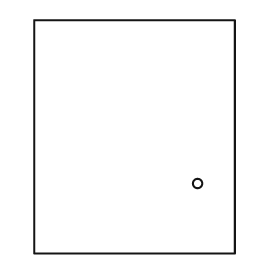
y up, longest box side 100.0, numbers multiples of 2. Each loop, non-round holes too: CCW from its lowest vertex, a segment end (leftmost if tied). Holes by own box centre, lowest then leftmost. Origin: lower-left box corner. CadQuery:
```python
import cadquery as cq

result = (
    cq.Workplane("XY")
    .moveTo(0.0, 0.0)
    .lineTo(86.0, 0.0)
    .lineTo(86.0, 100.0)
    .lineTo(0.0, 100.0)
    .close()
    .moveTo(70.0, 30.0)
    .circle(2.0)
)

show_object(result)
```